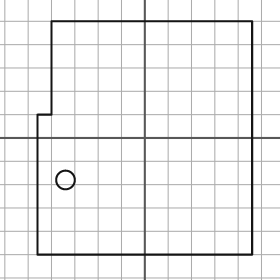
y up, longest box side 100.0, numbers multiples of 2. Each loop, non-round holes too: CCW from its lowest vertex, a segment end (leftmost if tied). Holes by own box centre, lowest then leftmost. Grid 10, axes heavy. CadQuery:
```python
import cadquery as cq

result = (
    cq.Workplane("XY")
    .moveTo(-46.0, -50.0)
    .lineTo(46.0, -50.0)
    .lineTo(46.0, 50.0)
    .lineTo(-40.0, 50.0)
    .lineTo(-40.0, 10.0)
    .lineTo(-46.0, 10.0)
    .close()
    .moveTo(-34.0, -18.0)
    .circle(4.0)
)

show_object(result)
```